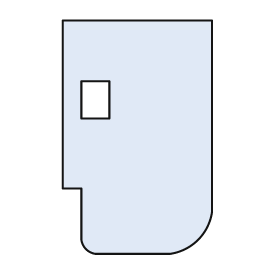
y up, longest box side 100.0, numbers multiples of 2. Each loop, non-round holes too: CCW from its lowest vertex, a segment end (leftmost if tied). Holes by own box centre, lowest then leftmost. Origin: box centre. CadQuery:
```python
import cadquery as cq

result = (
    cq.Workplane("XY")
    .moveTo(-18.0, -50.0)
    .lineTo(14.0, -50.0)
    .threePointArc((26.0, -44.0), (32.0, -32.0))
    .lineTo(32.0, 50.0)
    .lineTo(-32.0, 50.0)
    .lineTo(-32.0, -22.0)
    .lineTo(-24.0, -22.0)
    .lineTo(-24.0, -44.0)
    .threePointArc((-22.0, -48.0), (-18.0, -50.0))
    .close()
    .moveTo(-24.0, 8.0)
    .lineTo(-12.0, 8.0)
    .lineTo(-12.0, 24.0)
    .lineTo(-24.0, 24.0)
    .close()
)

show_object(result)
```